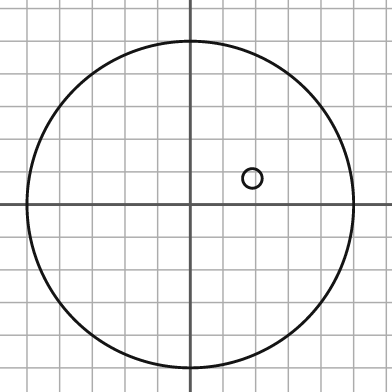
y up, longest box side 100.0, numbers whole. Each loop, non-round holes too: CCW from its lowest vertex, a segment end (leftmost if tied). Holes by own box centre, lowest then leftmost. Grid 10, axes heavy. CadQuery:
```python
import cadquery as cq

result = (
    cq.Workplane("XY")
    .moveTo(0.0, 0.0)
    .circle(50.0)
    .moveTo(19.0, 8.0)
    .circle(3.0)
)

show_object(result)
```